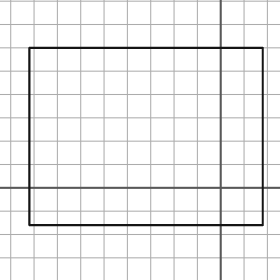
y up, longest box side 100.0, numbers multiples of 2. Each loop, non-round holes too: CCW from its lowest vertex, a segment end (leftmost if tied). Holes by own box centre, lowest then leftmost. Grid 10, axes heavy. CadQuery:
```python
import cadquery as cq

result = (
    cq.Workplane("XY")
    .moveTo(-82.0, -16.0)
    .lineTo(18.0, -16.0)
    .lineTo(18.0, 60.0)
    .lineTo(-82.0, 60.0)
    .close()
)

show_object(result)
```